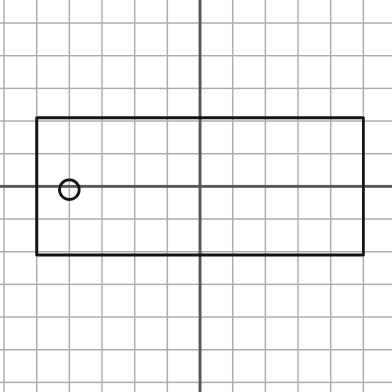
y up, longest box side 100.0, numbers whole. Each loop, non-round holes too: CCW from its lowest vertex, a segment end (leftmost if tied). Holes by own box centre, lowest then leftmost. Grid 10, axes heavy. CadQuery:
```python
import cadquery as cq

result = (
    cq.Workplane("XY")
    .moveTo(-50.0, -21.0)
    .lineTo(50.0, -21.0)
    .lineTo(50.0, 21.0)
    .lineTo(-50.0, 21.0)
    .close()
    .moveTo(-40.0, -1.0)
    .circle(3.0)
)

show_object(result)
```